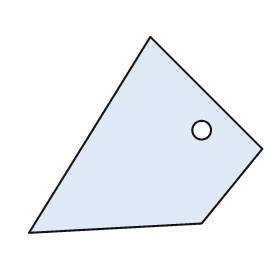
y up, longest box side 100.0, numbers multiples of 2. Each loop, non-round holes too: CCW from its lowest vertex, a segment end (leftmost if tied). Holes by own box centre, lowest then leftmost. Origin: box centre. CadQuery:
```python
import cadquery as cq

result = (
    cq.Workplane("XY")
    .moveTo(-50.0, -42.0)
    .lineTo(24.0, -38.0)
    .lineTo(50.0, -6.0)
    .lineTo(2.0, 42.0)
    .close()
    .moveTo(24.0, 2.0)
    .circle(4.0)
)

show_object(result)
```